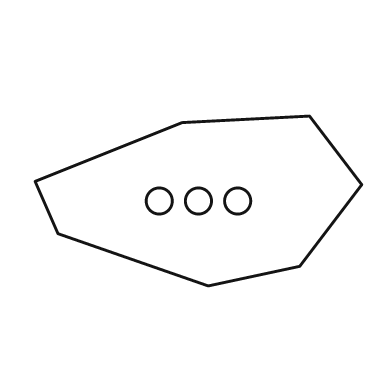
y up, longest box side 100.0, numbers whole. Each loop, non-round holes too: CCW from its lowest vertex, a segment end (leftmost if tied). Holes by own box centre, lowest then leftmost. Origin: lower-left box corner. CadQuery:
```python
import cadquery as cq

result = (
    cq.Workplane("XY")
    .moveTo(53.0, 0.0)
    .lineTo(81.0, 6.0)
    .lineTo(100.0, 31.0)
    .lineTo(84.0, 52.0)
    .lineTo(45.0, 50.0)
    .lineTo(0.0, 32.0)
    .lineTo(7.0, 16.0)
    .close()
    .moveTo(38.0, 26.0)
    .circle(4.0)
    .moveTo(50.0, 26.0)
    .circle(4.0)
    .moveTo(62.0, 26.0)
    .circle(4.0)
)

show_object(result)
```